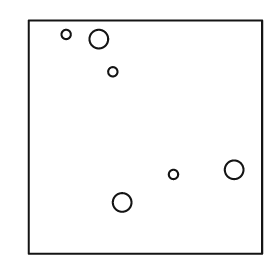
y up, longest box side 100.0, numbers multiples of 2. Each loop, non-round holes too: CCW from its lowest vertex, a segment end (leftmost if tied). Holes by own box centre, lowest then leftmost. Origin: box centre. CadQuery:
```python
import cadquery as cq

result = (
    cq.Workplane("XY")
    .moveTo(-50.0, -50.0)
    .lineTo(50.0, -50.0)
    .lineTo(50.0, 50.0)
    .lineTo(-50.0, 50.0)
    .close()
    .moveTo(-10.0, -28.0)
    .circle(4.0)
    .moveTo(12.0, -16.0)
    .circle(2.0)
    .moveTo(38.0, -14.0)
    .circle(4.0)
    .moveTo(-14.0, 28.0)
    .circle(2.0)
    .moveTo(-20.0, 42.0)
    .circle(4.0)
    .moveTo(-34.0, 44.0)
    .circle(2.0)
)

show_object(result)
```